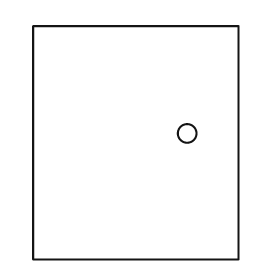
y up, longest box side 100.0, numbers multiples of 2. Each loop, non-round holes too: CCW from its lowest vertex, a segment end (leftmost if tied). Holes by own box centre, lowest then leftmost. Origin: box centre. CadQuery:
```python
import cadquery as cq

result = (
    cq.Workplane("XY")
    .moveTo(-44.0, -50.0)
    .lineTo(44.0, -50.0)
    .lineTo(44.0, 50.0)
    .lineTo(-44.0, 50.0)
    .close()
    .moveTo(22.0, 4.0)
    .circle(4.0)
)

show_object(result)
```